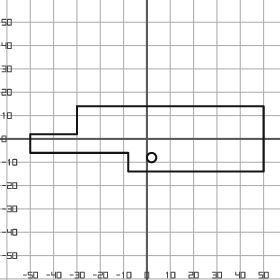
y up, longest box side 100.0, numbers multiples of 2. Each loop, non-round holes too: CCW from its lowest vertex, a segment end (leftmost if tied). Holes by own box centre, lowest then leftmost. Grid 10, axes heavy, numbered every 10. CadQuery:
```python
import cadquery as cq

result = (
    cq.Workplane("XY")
    .moveTo(-8.0, -14.0)
    .lineTo(50.0, -14.0)
    .lineTo(50.0, 14.0)
    .lineTo(-30.0, 14.0)
    .lineTo(-30.0, 2.0)
    .lineTo(-50.0, 2.0)
    .lineTo(-50.0, -6.0)
    .lineTo(-8.0, -6.0)
    .close()
    .moveTo(2.0, -8.0)
    .circle(2.0)
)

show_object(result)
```